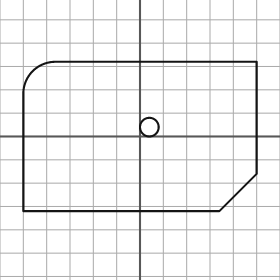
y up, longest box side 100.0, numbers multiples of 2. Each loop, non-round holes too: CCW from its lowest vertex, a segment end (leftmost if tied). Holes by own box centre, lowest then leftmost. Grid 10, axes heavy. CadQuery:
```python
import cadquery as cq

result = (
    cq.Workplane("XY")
    .moveTo(-50.0, -32.0)
    .lineTo(34.0, -32.0)
    .lineTo(50.0, -16.0)
    .lineTo(50.0, 32.0)
    .lineTo(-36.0, 32.0)
    .threePointArc((-46.0, 28.0), (-50.0, 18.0))
    .close()
    .moveTo(4.0, 4.0)
    .circle(4.0)
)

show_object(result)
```